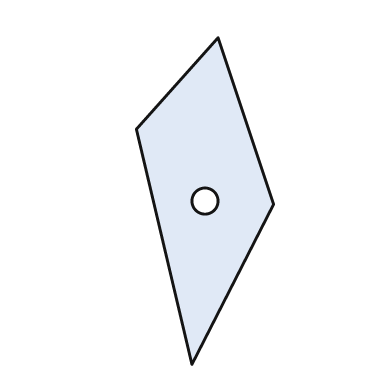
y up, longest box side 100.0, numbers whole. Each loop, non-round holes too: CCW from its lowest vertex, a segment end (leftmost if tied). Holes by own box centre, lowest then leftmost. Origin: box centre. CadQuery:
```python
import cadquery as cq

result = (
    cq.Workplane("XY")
    .moveTo(-4.0, -50.0)
    .lineTo(21.0, -1.0)
    .lineTo(4.0, 50.0)
    .lineTo(-21.0, 22.0)
    .close()
    .moveTo(0.0, 0.0)
    .circle(4.0)
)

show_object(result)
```